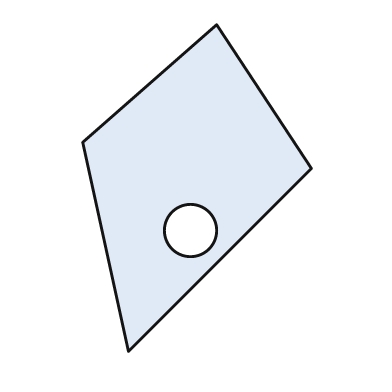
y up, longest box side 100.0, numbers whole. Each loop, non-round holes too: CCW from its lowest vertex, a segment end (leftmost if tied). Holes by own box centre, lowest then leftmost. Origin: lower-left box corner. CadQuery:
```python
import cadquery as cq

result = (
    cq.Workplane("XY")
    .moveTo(14.0, 0.0)
    .lineTo(70.0, 56.0)
    .lineTo(41.0, 100.0)
    .lineTo(0.0, 64.0)
    .close()
    .moveTo(33.0, 37.0)
    .circle(8.0)
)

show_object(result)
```